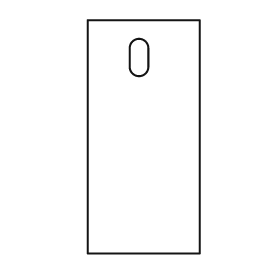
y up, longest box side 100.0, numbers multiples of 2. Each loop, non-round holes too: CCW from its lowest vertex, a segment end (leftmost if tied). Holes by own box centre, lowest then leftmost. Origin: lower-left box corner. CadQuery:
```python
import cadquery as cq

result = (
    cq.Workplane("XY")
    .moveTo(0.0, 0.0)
    .lineTo(48.0, 0.0)
    .lineTo(48.0, 100.0)
    .lineTo(0.0, 100.0)
    .close()
    .moveTo(18.0, 80.0)
    .threePointArc((22.0, 76.0), (26.0, 80.0))
    .lineTo(26.0, 88.0)
    .threePointArc((22.0, 92.0), (18.0, 88.0))
    .close()
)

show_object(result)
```